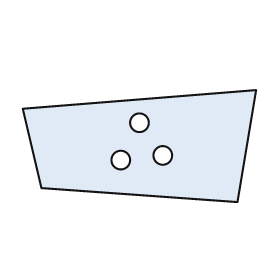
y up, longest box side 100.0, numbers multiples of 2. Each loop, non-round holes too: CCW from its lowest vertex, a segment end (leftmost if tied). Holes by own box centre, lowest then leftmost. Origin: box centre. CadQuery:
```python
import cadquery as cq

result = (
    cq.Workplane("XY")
    .moveTo(42.0, -24.0)
    .lineTo(50.0, 24.0)
    .lineTo(-50.0, 16.0)
    .lineTo(-42.0, -18.0)
    .close()
    .moveTo(-8.0, -6.0)
    .circle(4.0)
    .moveTo(10.0, -4.0)
    .circle(4.0)
    .moveTo(0.0, 10.0)
    .circle(4.0)
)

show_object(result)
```